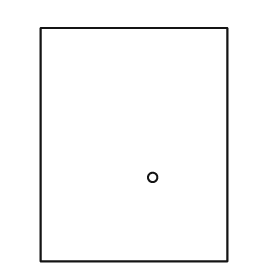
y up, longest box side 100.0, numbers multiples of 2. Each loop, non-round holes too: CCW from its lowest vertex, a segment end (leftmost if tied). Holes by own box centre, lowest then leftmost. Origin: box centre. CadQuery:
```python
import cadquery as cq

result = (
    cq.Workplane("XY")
    .moveTo(-40.0, -50.0)
    .lineTo(40.0, -50.0)
    .lineTo(40.0, 50.0)
    .lineTo(-40.0, 50.0)
    .close()
    .moveTo(8.0, -14.0)
    .circle(2.0)
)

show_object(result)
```